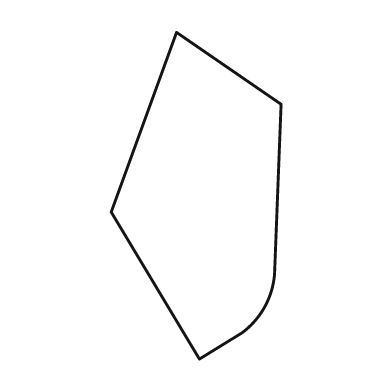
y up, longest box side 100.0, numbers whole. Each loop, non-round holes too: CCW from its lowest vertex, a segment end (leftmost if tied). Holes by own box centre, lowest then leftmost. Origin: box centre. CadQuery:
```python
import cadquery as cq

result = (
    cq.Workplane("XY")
    .moveTo(1.0, -50.0)
    .lineTo(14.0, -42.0)
    .threePointArc((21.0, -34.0), (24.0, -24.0))
    .lineTo(26.0, 28.0)
    .lineTo(-6.0, 50.0)
    .lineTo(-26.0, -5.0)
    .close()
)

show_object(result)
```